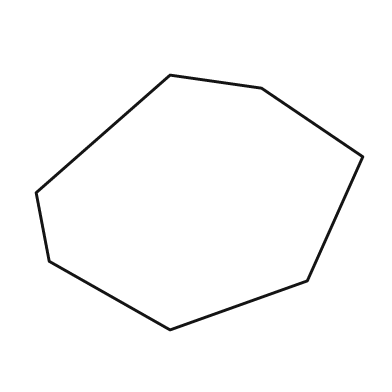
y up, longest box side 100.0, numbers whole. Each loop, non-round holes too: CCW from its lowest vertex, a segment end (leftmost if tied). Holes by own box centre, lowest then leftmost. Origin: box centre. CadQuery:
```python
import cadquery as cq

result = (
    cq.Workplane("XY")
    .moveTo(-9.0, -39.0)
    .lineTo(33.0, -24.0)
    .lineTo(50.0, 14.0)
    .lineTo(19.0, 35.0)
    .lineTo(-9.0, 39.0)
    .lineTo(-50.0, 3.0)
    .lineTo(-46.0, -18.0)
    .close()
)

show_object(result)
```